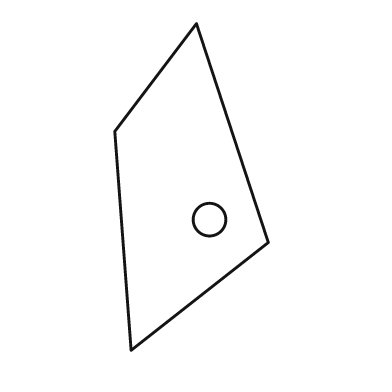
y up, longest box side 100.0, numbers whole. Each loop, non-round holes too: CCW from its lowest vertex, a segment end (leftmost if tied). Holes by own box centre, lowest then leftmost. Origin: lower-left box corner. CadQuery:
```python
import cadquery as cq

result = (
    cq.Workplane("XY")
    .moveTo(5.0, 0.0)
    .lineTo(47.0, 33.0)
    .lineTo(25.0, 100.0)
    .lineTo(0.0, 67.0)
    .close()
    .moveTo(29.0, 40.0)
    .circle(5.0)
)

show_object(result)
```